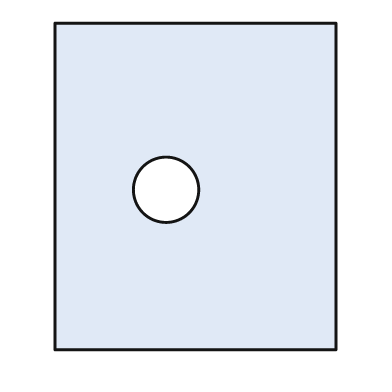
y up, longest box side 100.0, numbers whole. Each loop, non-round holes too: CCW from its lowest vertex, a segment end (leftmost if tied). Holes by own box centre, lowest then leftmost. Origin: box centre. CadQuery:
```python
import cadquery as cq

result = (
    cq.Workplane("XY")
    .moveTo(-43.0, -50.0)
    .lineTo(43.0, -50.0)
    .lineTo(43.0, 50.0)
    .lineTo(-43.0, 50.0)
    .close()
    .moveTo(-9.0, -1.0)
    .circle(10.0)
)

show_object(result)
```